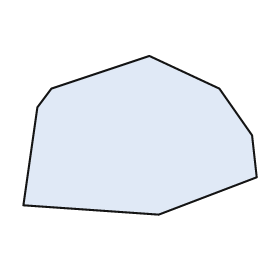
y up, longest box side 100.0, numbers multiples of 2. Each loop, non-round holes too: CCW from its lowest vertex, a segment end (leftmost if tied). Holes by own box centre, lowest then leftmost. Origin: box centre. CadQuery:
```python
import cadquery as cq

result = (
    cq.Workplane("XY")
    .moveTo(8.0, -34.0)
    .lineTo(50.0, -18.0)
    .lineTo(48.0, 0.0)
    .lineTo(34.0, 20.0)
    .lineTo(4.0, 34.0)
    .lineTo(-38.0, 20.0)
    .lineTo(-44.0, 12.0)
    .lineTo(-50.0, -30.0)
    .close()
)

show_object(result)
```